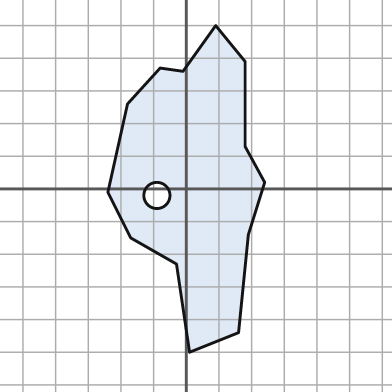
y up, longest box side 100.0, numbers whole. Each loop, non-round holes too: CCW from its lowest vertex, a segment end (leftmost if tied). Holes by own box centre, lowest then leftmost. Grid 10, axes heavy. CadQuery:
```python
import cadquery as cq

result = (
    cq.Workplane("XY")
    .moveTo(1.0, -50.0)
    .lineTo(16.0, -44.0)
    .lineTo(19.0, -14.0)
    .lineTo(24.0, 2.0)
    .lineTo(18.0, 13.0)
    .lineTo(18.0, 39.0)
    .lineTo(9.0, 50.0)
    .lineTo(-1.0, 36.0)
    .lineTo(-8.0, 37.0)
    .lineTo(-18.0, 26.0)
    .lineTo(-24.0, -1.0)
    .lineTo(-17.0, -15.0)
    .lineTo(-3.0, -23.0)
    .close()
    .moveTo(-9.0, -2.0)
    .circle(4.0)
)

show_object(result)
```